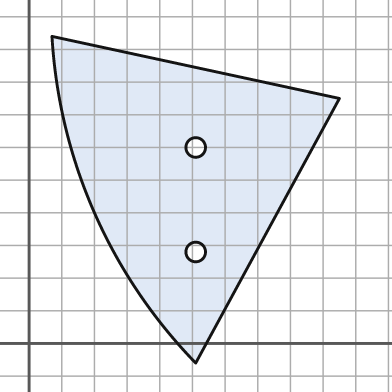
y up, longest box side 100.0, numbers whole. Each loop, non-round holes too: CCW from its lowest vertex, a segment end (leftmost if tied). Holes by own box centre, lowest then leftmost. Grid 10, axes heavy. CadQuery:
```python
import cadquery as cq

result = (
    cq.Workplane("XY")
    .moveTo(51.0, -6.0)
    .lineTo(95.0, 75.0)
    .lineTo(7.0, 94.0)
    .threePointArc((20.0, 40.0), (51.0, -6.0))
    .close()
    .moveTo(51.0, 28.0)
    .circle(3.0)
    .moveTo(51.0, 60.0)
    .circle(3.0)
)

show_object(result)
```